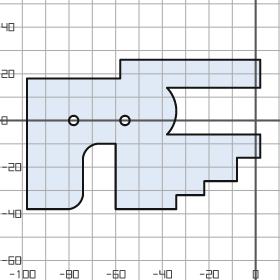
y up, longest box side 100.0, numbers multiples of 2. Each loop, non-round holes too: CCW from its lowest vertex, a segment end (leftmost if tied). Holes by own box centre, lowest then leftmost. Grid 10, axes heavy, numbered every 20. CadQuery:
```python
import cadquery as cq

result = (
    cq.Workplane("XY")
    .moveTo(-98.0, -38.0)
    .lineTo(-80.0, -38.0)
    .threePointArc((-76.0, -36.0), (-74.0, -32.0))
    .lineTo(-74.0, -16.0)
    .threePointArc((-72.0, -12.0), (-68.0, -10.0))
    .lineTo(-60.0, -10.0)
    .lineTo(-60.0, -38.0)
    .lineTo(-34.0, -38.0)
    .lineTo(-34.0, -32.0)
    .lineTo(-22.0, -32.0)
    .lineTo(-22.0, -26.0)
    .lineTo(-8.0, -26.0)
    .lineTo(-8.0, -16.0)
    .lineTo(2.0, -16.0)
    .lineTo(2.0, -6.0)
    .lineTo(-38.0, -6.0)
    .threePointArc((-34.0, 4.0), (-38.0, 14.0))
    .lineTo(2.0, 14.0)
    .lineTo(2.0, 26.0)
    .lineTo(-58.0, 26.0)
    .lineTo(-58.0, 18.0)
    .lineTo(-98.0, 18.0)
    .close()
    .moveTo(-78.0, 0.0)
    .circle(2.0)
    .moveTo(-56.0, 0.0)
    .circle(2.0)
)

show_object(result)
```